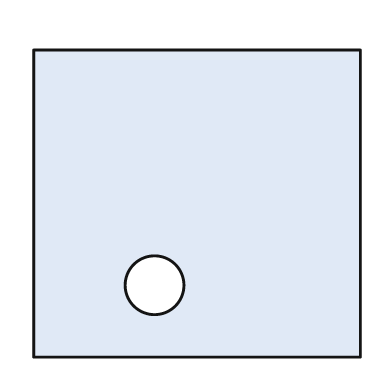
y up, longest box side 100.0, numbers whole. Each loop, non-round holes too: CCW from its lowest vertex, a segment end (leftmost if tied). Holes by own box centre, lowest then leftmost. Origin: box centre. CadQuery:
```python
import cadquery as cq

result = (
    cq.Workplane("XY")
    .moveTo(-50.0, -47.0)
    .lineTo(50.0, -47.0)
    .lineTo(50.0, 47.0)
    .lineTo(-50.0, 47.0)
    .close()
    .moveTo(-13.0, -25.0)
    .circle(9.0)
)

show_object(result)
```